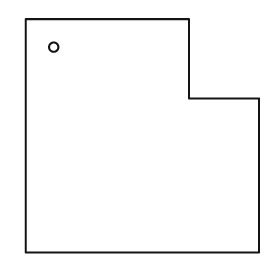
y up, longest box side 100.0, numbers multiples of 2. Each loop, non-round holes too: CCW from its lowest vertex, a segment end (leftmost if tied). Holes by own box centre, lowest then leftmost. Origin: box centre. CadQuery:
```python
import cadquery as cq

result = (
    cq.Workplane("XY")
    .moveTo(-50.0, -50.0)
    .lineTo(50.0, -50.0)
    .lineTo(50.0, 16.0)
    .lineTo(20.0, 16.0)
    .lineTo(20.0, 50.0)
    .lineTo(-50.0, 50.0)
    .close()
    .moveTo(-38.0, 38.0)
    .circle(2.0)
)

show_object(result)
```